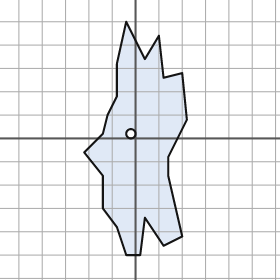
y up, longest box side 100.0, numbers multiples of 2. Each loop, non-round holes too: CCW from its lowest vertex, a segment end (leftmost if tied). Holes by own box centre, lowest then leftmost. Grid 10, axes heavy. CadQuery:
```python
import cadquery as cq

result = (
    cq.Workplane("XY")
    .moveTo(-4.0, -50.0)
    .lineTo(2.0, -50.0)
    .lineTo(4.0, -34.0)
    .lineTo(12.0, -46.0)
    .lineTo(20.0, -42.0)
    .lineTo(14.0, -16.0)
    .lineTo(14.0, -8.0)
    .lineTo(22.0, 8.0)
    .lineTo(20.0, 28.0)
    .lineTo(12.0, 26.0)
    .lineTo(10.0, 44.0)
    .lineTo(4.0, 34.0)
    .lineTo(-4.0, 50.0)
    .lineTo(-8.0, 32.0)
    .lineTo(-8.0, 18.0)
    .lineTo(-12.0, 10.0)
    .lineTo(-14.0, 2.0)
    .lineTo(-22.0, -6.0)
    .lineTo(-14.0, -16.0)
    .lineTo(-14.0, -30.0)
    .lineTo(-8.0, -38.0)
    .close()
    .moveTo(-2.0, 2.0)
    .circle(2.0)
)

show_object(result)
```